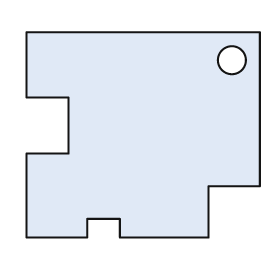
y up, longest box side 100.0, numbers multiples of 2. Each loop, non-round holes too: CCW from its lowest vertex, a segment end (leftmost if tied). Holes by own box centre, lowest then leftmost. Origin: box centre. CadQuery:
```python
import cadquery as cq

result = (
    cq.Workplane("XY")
    .moveTo(-50.0, -44.0)
    .lineTo(-24.0, -44.0)
    .lineTo(-24.0, -36.0)
    .lineTo(-10.0, -36.0)
    .lineTo(-10.0, -44.0)
    .lineTo(28.0, -44.0)
    .lineTo(28.0, -22.0)
    .lineTo(50.0, -22.0)
    .lineTo(50.0, 44.0)
    .lineTo(-50.0, 44.0)
    .lineTo(-50.0, 16.0)
    .lineTo(-32.0, 16.0)
    .lineTo(-32.0, -8.0)
    .lineTo(-50.0, -8.0)
    .close()
    .moveTo(38.0, 32.0)
    .circle(6.0)
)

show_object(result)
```